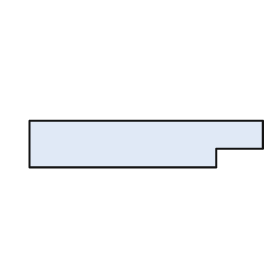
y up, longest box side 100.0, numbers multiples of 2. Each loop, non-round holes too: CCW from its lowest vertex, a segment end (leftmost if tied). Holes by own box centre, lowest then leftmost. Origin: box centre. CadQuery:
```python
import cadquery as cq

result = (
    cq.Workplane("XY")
    .moveTo(-50.0, -10.0)
    .lineTo(30.0, -10.0)
    .lineTo(30.0, -2.0)
    .lineTo(50.0, -2.0)
    .lineTo(50.0, 10.0)
    .lineTo(-50.0, 10.0)
    .close()
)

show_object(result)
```